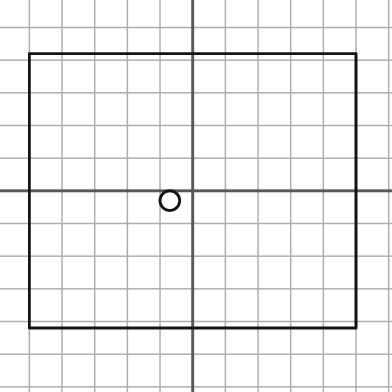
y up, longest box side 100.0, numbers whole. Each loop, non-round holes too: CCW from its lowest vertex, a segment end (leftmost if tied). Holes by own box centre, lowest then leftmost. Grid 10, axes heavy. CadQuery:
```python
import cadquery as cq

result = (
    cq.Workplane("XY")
    .moveTo(-50.0, -42.0)
    .lineTo(50.0, -42.0)
    .lineTo(50.0, 42.0)
    .lineTo(-50.0, 42.0)
    .close()
    .moveTo(-7.0, -3.0)
    .circle(3.0)
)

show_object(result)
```